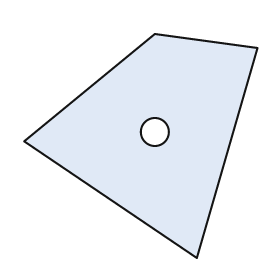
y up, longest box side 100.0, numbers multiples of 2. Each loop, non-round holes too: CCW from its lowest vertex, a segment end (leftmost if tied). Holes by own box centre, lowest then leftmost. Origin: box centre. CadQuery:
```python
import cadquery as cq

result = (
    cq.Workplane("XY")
    .moveTo(24.0, -48.0)
    .lineTo(50.0, 42.0)
    .lineTo(6.0, 48.0)
    .lineTo(-50.0, 2.0)
    .close()
    .moveTo(6.0, 6.0)
    .circle(6.0)
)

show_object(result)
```